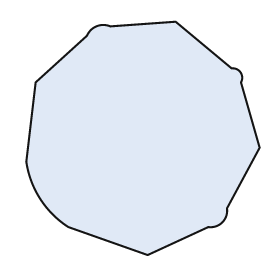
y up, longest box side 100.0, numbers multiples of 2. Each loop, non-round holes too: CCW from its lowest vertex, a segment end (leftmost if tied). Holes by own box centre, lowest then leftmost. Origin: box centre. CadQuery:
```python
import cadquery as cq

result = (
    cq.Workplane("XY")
    .moveTo(2.0, -50.0)
    .lineTo(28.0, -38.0)
    .threePointArc((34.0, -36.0), (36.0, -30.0))
    .lineTo(50.0, -4.0)
    .lineTo(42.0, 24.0)
    .threePointArc((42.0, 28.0), (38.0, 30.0))
    .lineTo(14.0, 50.0)
    .lineTo(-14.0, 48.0)
    .threePointArc((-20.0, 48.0), (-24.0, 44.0))
    .lineTo(-46.0, 24.0)
    .lineTo(-50.0, -10.0)
    .threePointArc((-44.0, -26.0), (-32.0, -38.0))
    .close()
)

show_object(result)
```